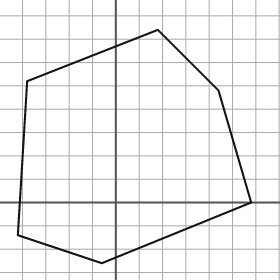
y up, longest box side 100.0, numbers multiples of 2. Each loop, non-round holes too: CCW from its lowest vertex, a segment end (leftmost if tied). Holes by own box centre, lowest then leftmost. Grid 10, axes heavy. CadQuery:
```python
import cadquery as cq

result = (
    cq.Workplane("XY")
    .moveTo(-6.0, -26.0)
    .lineTo(58.0, 0.0)
    .lineTo(44.0, 48.0)
    .lineTo(18.0, 74.0)
    .lineTo(-38.0, 52.0)
    .lineTo(-42.0, -14.0)
    .close()
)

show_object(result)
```